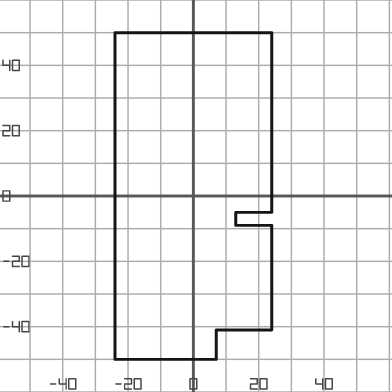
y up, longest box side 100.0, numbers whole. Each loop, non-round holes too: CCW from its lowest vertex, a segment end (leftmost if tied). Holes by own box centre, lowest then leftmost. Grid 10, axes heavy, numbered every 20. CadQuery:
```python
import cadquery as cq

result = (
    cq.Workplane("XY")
    .moveTo(-24.0, -50.0)
    .lineTo(7.0, -50.0)
    .lineTo(7.0, -41.0)
    .lineTo(24.0, -41.0)
    .lineTo(24.0, -9.0)
    .lineTo(13.0, -9.0)
    .lineTo(13.0, -5.0)
    .lineTo(24.0, -5.0)
    .lineTo(24.0, 50.0)
    .lineTo(-24.0, 50.0)
    .close()
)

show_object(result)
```